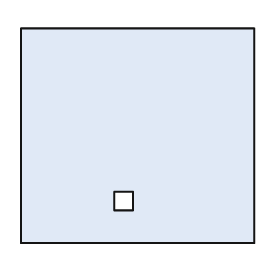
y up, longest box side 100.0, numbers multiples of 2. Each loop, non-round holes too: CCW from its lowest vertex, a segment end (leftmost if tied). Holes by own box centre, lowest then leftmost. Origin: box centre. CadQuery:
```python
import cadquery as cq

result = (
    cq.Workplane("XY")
    .moveTo(-50.0, -46.0)
    .lineTo(50.0, -46.0)
    .lineTo(50.0, 46.0)
    .lineTo(-50.0, 46.0)
    .close()
    .moveTo(-10.0, -32.0)
    .lineTo(-2.0, -32.0)
    .lineTo(-2.0, -24.0)
    .lineTo(-10.0, -24.0)
    .close()
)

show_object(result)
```